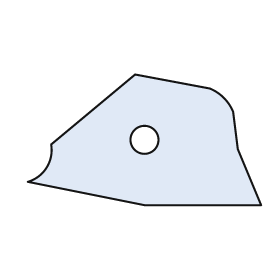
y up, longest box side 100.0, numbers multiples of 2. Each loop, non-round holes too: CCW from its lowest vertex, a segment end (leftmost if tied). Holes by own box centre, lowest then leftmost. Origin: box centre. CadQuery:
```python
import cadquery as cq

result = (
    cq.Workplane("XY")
    .moveTo(0.0, -28.0)
    .lineTo(50.0, -28.0)
    .lineTo(40.0, -4.0)
    .lineTo(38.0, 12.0)
    .threePointArc((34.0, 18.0), (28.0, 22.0))
    .lineTo(-4.0, 28.0)
    .lineTo(-40.0, -2.0)
    .threePointArc((-42.0, -12.0), (-50.0, -18.0))
    .close()
    .moveTo(0.0, 0.0)
    .circle(6.0)
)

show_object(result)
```